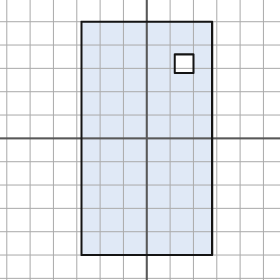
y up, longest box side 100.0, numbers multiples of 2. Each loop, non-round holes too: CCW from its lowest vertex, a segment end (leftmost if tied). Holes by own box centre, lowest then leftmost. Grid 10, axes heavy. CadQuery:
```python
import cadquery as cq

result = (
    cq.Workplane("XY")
    .moveTo(-28.0, -50.0)
    .lineTo(28.0, -50.0)
    .lineTo(28.0, 50.0)
    .lineTo(-28.0, 50.0)
    .close()
    .moveTo(12.0, 28.0)
    .lineTo(20.0, 28.0)
    .lineTo(20.0, 36.0)
    .lineTo(12.0, 36.0)
    .close()
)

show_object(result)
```